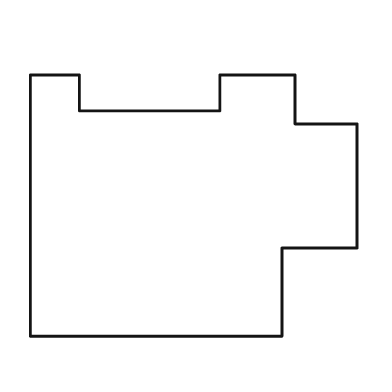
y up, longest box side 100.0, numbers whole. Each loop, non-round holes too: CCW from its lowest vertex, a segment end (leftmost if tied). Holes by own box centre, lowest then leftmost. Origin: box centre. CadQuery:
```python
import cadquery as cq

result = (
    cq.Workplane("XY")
    .moveTo(-50.0, -40.0)
    .lineTo(27.0, -40.0)
    .lineTo(27.0, -13.0)
    .lineTo(50.0, -13.0)
    .lineTo(50.0, 25.0)
    .lineTo(31.0, 25.0)
    .lineTo(31.0, 40.0)
    .lineTo(8.0, 40.0)
    .lineTo(8.0, 29.0)
    .lineTo(-35.0, 29.0)
    .lineTo(-35.0, 40.0)
    .lineTo(-50.0, 40.0)
    .close()
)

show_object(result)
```